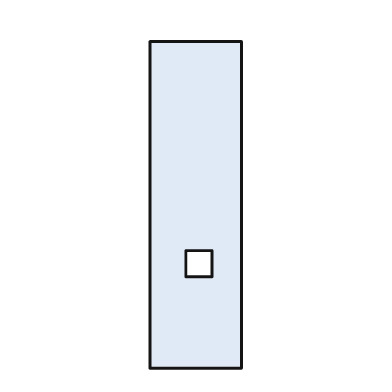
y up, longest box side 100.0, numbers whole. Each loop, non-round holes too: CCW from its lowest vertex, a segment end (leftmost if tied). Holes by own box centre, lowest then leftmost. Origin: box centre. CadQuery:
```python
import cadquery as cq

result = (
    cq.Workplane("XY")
    .moveTo(-14.0, -50.0)
    .lineTo(14.0, -50.0)
    .lineTo(14.0, 50.0)
    .lineTo(-14.0, 50.0)
    .close()
    .moveTo(-3.0, -22.0)
    .lineTo(5.0, -22.0)
    .lineTo(5.0, -14.0)
    .lineTo(-3.0, -14.0)
    .close()
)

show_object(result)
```